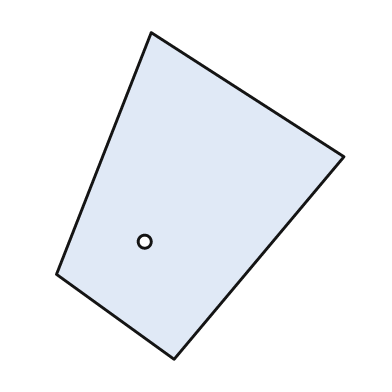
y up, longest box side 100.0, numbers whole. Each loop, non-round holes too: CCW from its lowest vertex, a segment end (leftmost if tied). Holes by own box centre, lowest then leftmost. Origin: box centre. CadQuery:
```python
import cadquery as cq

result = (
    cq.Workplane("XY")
    .moveTo(-8.0, -50.0)
    .lineTo(44.0, 12.0)
    .lineTo(-15.0, 50.0)
    .lineTo(-44.0, -24.0)
    .close()
    .moveTo(-17.0, -14.0)
    .circle(2.0)
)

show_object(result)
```